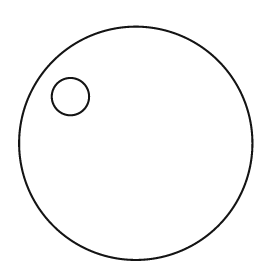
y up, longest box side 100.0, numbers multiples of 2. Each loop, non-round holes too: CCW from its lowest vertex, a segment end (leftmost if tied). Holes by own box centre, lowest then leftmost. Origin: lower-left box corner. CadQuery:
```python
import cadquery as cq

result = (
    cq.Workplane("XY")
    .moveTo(50.0, 50.0)
    .circle(50.0)
    .moveTo(22.0, 70.0)
    .circle(8.0)
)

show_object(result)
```